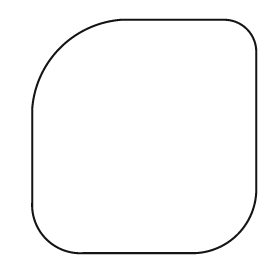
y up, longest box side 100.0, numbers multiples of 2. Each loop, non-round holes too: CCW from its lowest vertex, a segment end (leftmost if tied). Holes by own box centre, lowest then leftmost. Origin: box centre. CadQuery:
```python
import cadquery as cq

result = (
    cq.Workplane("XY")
    .moveTo(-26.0, -50.0)
    .lineTo(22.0, -50.0)
    .threePointArc((40.0, -42.0), (48.0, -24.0))
    .lineTo(48.0, 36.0)
    .threePointArc((44.0, 46.0), (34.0, 50.0))
    .lineTo(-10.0, 50.0)
    .threePointArc((-36.0, 38.0), (-48.0, 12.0))
    .lineTo(-48.0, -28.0)
    .threePointArc((-42.0, -44.0), (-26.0, -50.0))
    .close()
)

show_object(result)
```